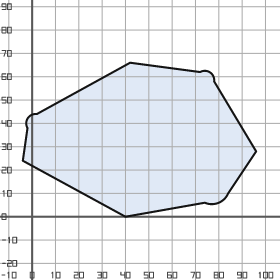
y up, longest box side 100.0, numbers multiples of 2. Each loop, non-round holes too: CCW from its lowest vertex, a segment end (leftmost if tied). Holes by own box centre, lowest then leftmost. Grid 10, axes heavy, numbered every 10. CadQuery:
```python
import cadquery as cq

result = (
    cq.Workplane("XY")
    .moveTo(40.0, 0.0)
    .lineTo(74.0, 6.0)
    .threePointArc((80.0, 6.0), (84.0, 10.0))
    .lineTo(96.0, 28.0)
    .lineTo(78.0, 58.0)
    .threePointArc((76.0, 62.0), (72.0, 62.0))
    .lineTo(42.0, 66.0)
    .lineTo(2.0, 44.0)
    .threePointArc((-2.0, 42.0), (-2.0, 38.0))
    .lineTo(-4.0, 24.0)
    .close()
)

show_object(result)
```